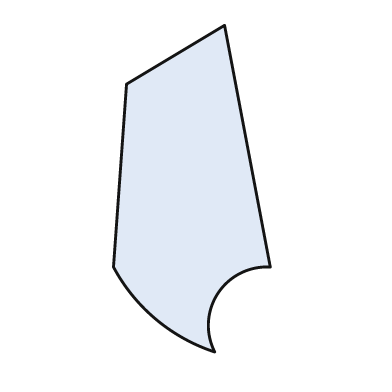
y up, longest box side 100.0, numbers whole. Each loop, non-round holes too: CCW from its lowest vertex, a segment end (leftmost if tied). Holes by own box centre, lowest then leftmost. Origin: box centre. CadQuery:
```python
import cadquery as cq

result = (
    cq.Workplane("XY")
    .moveTo(7.0, -50.0)
    .threePointArc((8.0, -32.0), (24.0, -24.0))
    .lineTo(10.0, 50.0)
    .lineTo(-20.0, 32.0)
    .lineTo(-24.0, -24.0)
    .threePointArc((-11.0, -40.0), (7.0, -50.0))
    .close()
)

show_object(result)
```